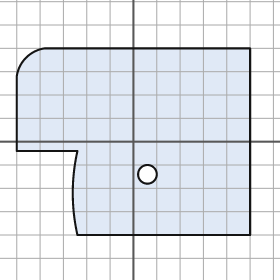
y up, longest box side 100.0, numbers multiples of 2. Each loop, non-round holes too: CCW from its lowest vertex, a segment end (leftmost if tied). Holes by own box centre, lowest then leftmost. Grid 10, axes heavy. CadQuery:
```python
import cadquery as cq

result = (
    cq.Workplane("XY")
    .moveTo(-24.0, -40.0)
    .lineTo(50.0, -40.0)
    .lineTo(50.0, 40.0)
    .lineTo(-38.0, 40.0)
    .threePointArc((-46.0, 36.0), (-50.0, 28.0))
    .lineTo(-50.0, -4.0)
    .lineTo(-24.0, -4.0)
    .threePointArc((-26.0, -22.0), (-24.0, -40.0))
    .close()
    .moveTo(6.0, -14.0)
    .circle(4.0)
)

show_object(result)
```